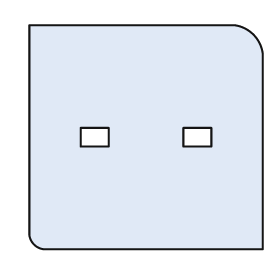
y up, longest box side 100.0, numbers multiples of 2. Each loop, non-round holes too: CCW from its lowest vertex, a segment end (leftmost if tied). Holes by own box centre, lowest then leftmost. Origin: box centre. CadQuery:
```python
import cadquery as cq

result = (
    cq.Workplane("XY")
    .moveTo(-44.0, -48.0)
    .lineTo(50.0, -48.0)
    .lineTo(50.0, 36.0)
    .threePointArc((46.0, 44.0), (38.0, 48.0))
    .lineTo(-50.0, 48.0)
    .lineTo(-50.0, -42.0)
    .threePointArc((-48.0, -46.0), (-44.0, -48.0))
    .close()
    .moveTo(-28.0, -4.0)
    .lineTo(-16.0, -4.0)
    .lineTo(-16.0, 4.0)
    .lineTo(-28.0, 4.0)
    .close()
    .moveTo(16.0, -4.0)
    .lineTo(28.0, -4.0)
    .lineTo(28.0, 4.0)
    .lineTo(16.0, 4.0)
    .close()
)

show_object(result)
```